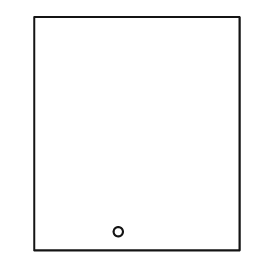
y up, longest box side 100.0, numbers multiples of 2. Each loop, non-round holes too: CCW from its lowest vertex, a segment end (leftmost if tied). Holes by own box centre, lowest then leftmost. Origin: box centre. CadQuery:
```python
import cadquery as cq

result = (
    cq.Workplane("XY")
    .moveTo(-44.0, -50.0)
    .lineTo(44.0, -50.0)
    .lineTo(44.0, 50.0)
    .lineTo(-44.0, 50.0)
    .close()
    .moveTo(-8.0, -42.0)
    .circle(2.0)
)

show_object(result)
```